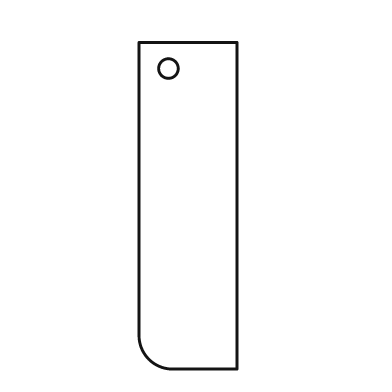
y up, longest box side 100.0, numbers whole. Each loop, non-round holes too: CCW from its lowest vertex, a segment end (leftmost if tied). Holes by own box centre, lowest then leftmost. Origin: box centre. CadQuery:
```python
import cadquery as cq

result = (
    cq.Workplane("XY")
    .moveTo(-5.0, -50.0)
    .lineTo(15.0, -50.0)
    .lineTo(15.0, 50.0)
    .lineTo(-15.0, 50.0)
    .lineTo(-15.0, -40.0)
    .threePointArc((-12.0, -47.0), (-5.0, -50.0))
    .close()
    .moveTo(-6.0, 42.0)
    .circle(3.0)
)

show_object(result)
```